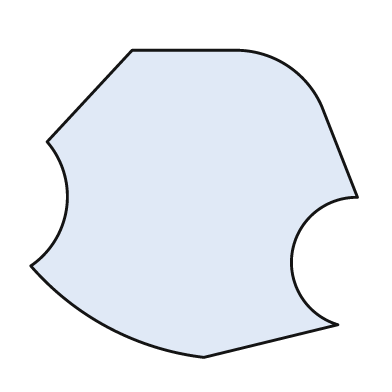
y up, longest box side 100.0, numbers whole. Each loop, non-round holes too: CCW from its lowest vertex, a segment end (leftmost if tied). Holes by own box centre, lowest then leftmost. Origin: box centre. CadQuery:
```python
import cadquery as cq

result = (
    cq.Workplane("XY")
    .moveTo(3.0, -47.0)
    .lineTo(44.0, -37.0)
    .threePointArc((30.0, -15.0), (50.0, 2.0))
    .lineTo(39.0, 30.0)
    .threePointArc((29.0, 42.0), (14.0, 47.0))
    .lineTo(-19.0, 47.0)
    .lineTo(-45.0, 19.0)
    .threePointArc((-39.0, -1.0), (-50.0, -19.0))
    .threePointArc((-26.0, -38.0), (3.0, -47.0))
    .close()
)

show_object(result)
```